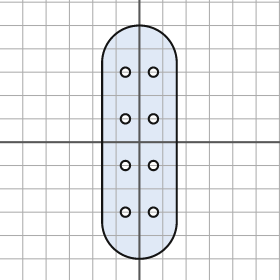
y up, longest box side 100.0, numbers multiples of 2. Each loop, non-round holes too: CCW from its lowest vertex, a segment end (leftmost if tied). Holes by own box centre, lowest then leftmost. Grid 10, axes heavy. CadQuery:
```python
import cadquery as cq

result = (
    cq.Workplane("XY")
    .moveTo(-16.0, -34.0)
    .threePointArc((0.0, -50.0), (16.0, -34.0))
    .lineTo(16.0, 34.0)
    .threePointArc((0.0, 50.0), (-16.0, 34.0))
    .close()
    .moveTo(-6.0, -30.0)
    .circle(2.0)
    .moveTo(6.0, -30.0)
    .circle(2.0)
    .moveTo(-6.0, -10.0)
    .circle(2.0)
    .moveTo(6.0, -10.0)
    .circle(2.0)
    .moveTo(-6.0, 10.0)
    .circle(2.0)
    .moveTo(6.0, 10.0)
    .circle(2.0)
    .moveTo(-6.0, 30.0)
    .circle(2.0)
    .moveTo(6.0, 30.0)
    .circle(2.0)
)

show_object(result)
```